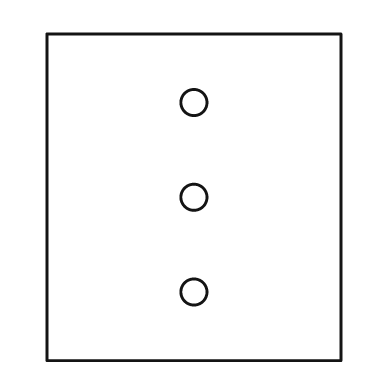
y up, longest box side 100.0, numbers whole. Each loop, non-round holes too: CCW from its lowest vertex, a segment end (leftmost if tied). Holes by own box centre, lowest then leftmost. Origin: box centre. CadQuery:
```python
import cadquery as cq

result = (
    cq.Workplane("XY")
    .moveTo(-45.0, -50.0)
    .lineTo(45.0, -50.0)
    .lineTo(45.0, 50.0)
    .lineTo(-45.0, 50.0)
    .close()
    .moveTo(0.0, -29.0)
    .circle(4.0)
    .moveTo(0.0, 0.0)
    .circle(4.0)
    .moveTo(0.0, 29.0)
    .circle(4.0)
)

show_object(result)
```